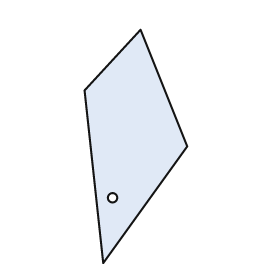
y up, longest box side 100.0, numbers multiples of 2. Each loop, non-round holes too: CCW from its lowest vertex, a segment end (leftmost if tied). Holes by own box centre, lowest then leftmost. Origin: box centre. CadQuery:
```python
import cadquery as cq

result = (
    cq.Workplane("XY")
    .moveTo(-14.0, -50.0)
    .lineTo(22.0, 0.0)
    .lineTo(2.0, 50.0)
    .lineTo(-22.0, 24.0)
    .close()
    .moveTo(-10.0, -22.0)
    .circle(2.0)
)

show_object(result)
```